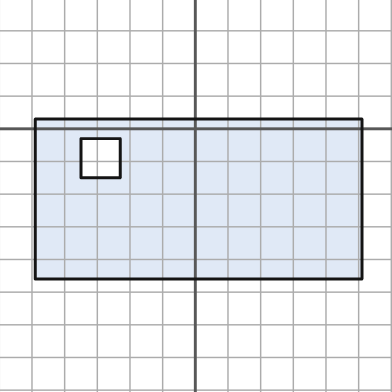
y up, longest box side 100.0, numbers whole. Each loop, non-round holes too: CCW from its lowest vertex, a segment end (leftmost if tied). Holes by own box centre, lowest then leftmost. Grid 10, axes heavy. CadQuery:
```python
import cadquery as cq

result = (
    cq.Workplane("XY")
    .moveTo(-49.0, -46.0)
    .lineTo(51.0, -46.0)
    .lineTo(51.0, 3.0)
    .lineTo(-49.0, 3.0)
    .close()
    .moveTo(-35.0, -15.0)
    .lineTo(-23.0, -15.0)
    .lineTo(-23.0, -3.0)
    .lineTo(-35.0, -3.0)
    .close()
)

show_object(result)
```